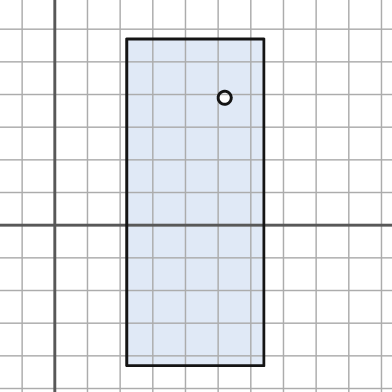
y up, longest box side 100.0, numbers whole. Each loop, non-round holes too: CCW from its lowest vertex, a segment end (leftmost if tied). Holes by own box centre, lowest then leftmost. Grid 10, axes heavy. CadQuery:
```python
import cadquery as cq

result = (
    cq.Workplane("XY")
    .moveTo(22.0, -43.0)
    .lineTo(64.0, -43.0)
    .lineTo(64.0, 57.0)
    .lineTo(22.0, 57.0)
    .close()
    .moveTo(52.0, 39.0)
    .circle(2.0)
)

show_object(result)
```